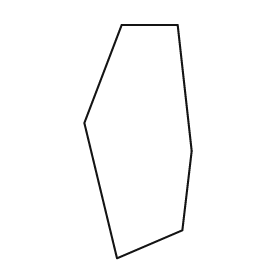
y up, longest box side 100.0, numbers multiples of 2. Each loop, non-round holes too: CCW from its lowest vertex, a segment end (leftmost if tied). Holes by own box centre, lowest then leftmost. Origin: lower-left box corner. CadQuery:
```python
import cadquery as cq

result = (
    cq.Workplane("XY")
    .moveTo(14.0, 0.0)
    .lineTo(42.0, 12.0)
    .lineTo(46.0, 46.0)
    .lineTo(40.0, 100.0)
    .lineTo(16.0, 100.0)
    .lineTo(0.0, 58.0)
    .close()
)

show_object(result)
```